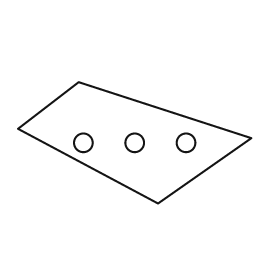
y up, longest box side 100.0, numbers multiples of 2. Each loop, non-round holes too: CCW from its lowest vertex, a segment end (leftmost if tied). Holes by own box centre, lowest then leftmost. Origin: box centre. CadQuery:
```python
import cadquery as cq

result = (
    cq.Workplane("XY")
    .moveTo(10.0, -26.0)
    .lineTo(50.0, 2.0)
    .lineTo(-24.0, 26.0)
    .lineTo(-50.0, 6.0)
    .close()
    .moveTo(-22.0, 0.0)
    .circle(4.0)
    .moveTo(0.0, 0.0)
    .circle(4.0)
    .moveTo(22.0, 0.0)
    .circle(4.0)
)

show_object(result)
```